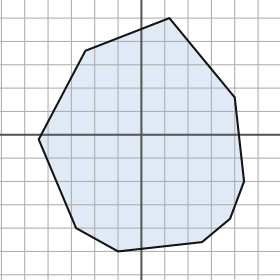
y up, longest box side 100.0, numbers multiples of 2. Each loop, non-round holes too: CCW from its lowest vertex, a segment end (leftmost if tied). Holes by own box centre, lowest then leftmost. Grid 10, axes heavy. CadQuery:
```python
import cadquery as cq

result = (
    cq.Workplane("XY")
    .moveTo(-10.0, -50.0)
    .lineTo(26.0, -46.0)
    .lineTo(38.0, -36.0)
    .lineTo(44.0, -20.0)
    .lineTo(40.0, 16.0)
    .lineTo(12.0, 50.0)
    .lineTo(-24.0, 36.0)
    .lineTo(-44.0, -2.0)
    .lineTo(-28.0, -40.0)
    .close()
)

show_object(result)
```